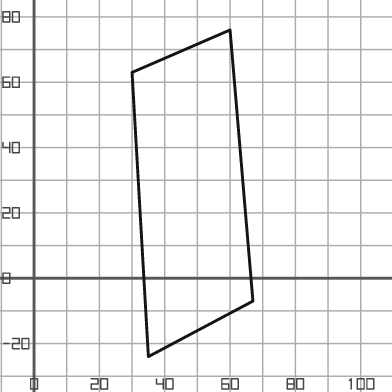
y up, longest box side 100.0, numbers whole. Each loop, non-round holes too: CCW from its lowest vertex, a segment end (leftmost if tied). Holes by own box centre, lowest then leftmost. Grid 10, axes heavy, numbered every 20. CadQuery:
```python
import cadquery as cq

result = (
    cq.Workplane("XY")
    .moveTo(35.0, -24.0)
    .lineTo(67.0, -7.0)
    .lineTo(60.0, 76.0)
    .lineTo(30.0, 63.0)
    .close()
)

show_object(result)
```